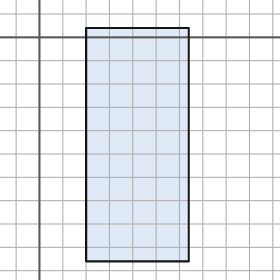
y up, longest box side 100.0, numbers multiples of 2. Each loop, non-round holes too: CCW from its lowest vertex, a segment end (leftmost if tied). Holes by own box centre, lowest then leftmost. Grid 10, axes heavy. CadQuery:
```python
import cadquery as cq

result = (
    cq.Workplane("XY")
    .moveTo(20.0, -96.0)
    .lineTo(64.0, -96.0)
    .lineTo(64.0, 4.0)
    .lineTo(20.0, 4.0)
    .close()
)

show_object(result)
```